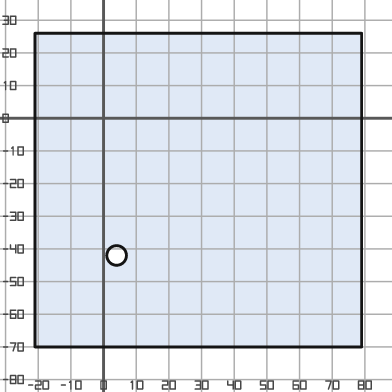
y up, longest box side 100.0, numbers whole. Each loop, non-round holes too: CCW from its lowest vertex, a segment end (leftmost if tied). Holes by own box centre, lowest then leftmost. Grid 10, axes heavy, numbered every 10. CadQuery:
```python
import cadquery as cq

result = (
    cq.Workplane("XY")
    .moveTo(-21.0, -70.0)
    .lineTo(79.0, -70.0)
    .lineTo(79.0, 26.0)
    .lineTo(-21.0, 26.0)
    .close()
    .moveTo(4.0, -42.0)
    .circle(3.0)
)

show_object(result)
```